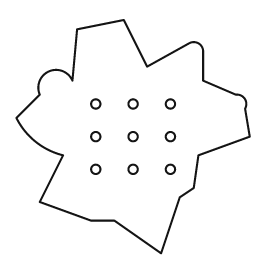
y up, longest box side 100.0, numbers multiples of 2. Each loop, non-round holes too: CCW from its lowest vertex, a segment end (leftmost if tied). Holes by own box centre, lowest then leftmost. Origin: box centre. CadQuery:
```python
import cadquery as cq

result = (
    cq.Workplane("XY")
    .moveTo(12.0, -50.0)
    .lineTo(20.0, -26.0)
    .lineTo(26.0, -22.0)
    .lineTo(28.0, -8.0)
    .lineTo(50.0, 0.0)
    .lineTo(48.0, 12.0)
    .threePointArc((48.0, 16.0), (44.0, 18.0))
    .lineTo(30.0, 24.0)
    .lineTo(30.0, 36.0)
    .threePointArc((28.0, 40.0), (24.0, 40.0))
    .lineTo(6.0, 30.0)
    .lineTo(-4.0, 50.0)
    .lineTo(-24.0, 46.0)
    .lineTo(-26.0, 24.0)
    .threePointArc((-36.0, 28.0), (-40.0, 18.0))
    .lineTo(-50.0, 8.0)
    .threePointArc((-42.0, -2.0), (-30.0, -8.0))
    .lineTo(-40.0, -28.0)
    .lineTo(-18.0, -36.0)
    .lineTo(-8.0, -36.0)
    .close()
    .moveTo(-16.0, -14.0)
    .circle(2.0)
    .moveTo(0.0, -14.0)
    .circle(2.0)
    .moveTo(16.0, -14.0)
    .circle(2.0)
    .moveTo(-16.0, 0.0)
    .circle(2.0)
    .moveTo(0.0, 0.0)
    .circle(2.0)
    .moveTo(16.0, 0.0)
    .circle(2.0)
    .moveTo(-16.0, 14.0)
    .circle(2.0)
    .moveTo(0.0, 14.0)
    .circle(2.0)
    .moveTo(16.0, 14.0)
    .circle(2.0)
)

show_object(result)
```